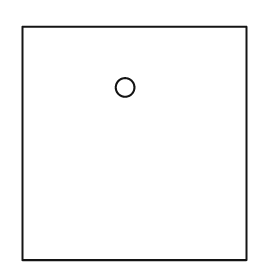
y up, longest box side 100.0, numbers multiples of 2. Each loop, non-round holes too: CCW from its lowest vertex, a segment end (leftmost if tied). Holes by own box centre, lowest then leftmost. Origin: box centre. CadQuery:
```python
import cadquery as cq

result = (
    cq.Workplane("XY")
    .moveTo(-48.0, -50.0)
    .lineTo(48.0, -50.0)
    .lineTo(48.0, 50.0)
    .lineTo(-48.0, 50.0)
    .close()
    .moveTo(-4.0, 24.0)
    .circle(4.0)
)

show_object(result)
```